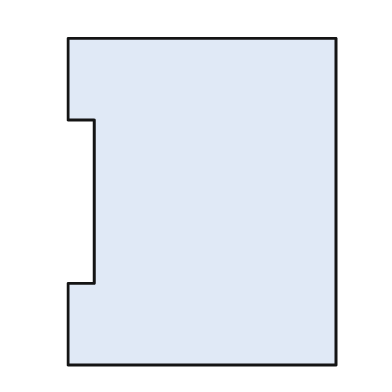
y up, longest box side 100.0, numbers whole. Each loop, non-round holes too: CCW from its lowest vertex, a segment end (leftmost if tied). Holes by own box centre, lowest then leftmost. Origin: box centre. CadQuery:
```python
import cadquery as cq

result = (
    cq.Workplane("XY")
    .moveTo(-41.0, -50.0)
    .lineTo(41.0, -50.0)
    .lineTo(41.0, 50.0)
    .lineTo(-41.0, 50.0)
    .lineTo(-41.0, 25.0)
    .lineTo(-33.0, 25.0)
    .lineTo(-33.0, -25.0)
    .lineTo(-41.0, -25.0)
    .close()
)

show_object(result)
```